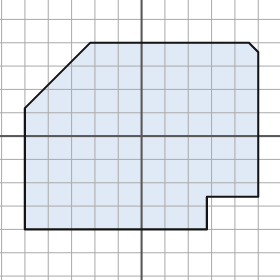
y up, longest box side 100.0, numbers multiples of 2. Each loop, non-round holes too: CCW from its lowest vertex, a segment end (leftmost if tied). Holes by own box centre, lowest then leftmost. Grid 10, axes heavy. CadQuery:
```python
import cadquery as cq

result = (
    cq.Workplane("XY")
    .moveTo(-50.0, -40.0)
    .lineTo(28.0, -40.0)
    .lineTo(28.0, -26.0)
    .lineTo(50.0, -26.0)
    .lineTo(50.0, 36.0)
    .lineTo(46.0, 40.0)
    .lineTo(-22.0, 40.0)
    .lineTo(-50.0, 12.0)
    .close()
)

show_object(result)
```